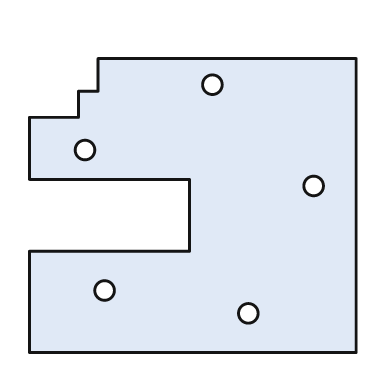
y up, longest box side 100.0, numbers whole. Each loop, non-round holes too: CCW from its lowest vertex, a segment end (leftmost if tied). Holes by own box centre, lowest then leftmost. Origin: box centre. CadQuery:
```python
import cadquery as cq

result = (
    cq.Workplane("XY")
    .moveTo(-50.0, -45.0)
    .lineTo(50.0, -45.0)
    .lineTo(50.0, 45.0)
    .lineTo(-29.0, 45.0)
    .lineTo(-29.0, 35.0)
    .lineTo(-35.0, 35.0)
    .lineTo(-35.0, 27.0)
    .lineTo(-50.0, 27.0)
    .lineTo(-50.0, 8.0)
    .lineTo(-1.0, 8.0)
    .lineTo(-1.0, -14.0)
    .lineTo(-50.0, -14.0)
    .close()
    .moveTo(17.0, -33.0)
    .circle(3.0)
    .moveTo(-27.0, -26.0)
    .circle(3.0)
    .moveTo(37.0, 6.0)
    .circle(3.0)
    .moveTo(-33.0, 17.0)
    .circle(3.0)
    .moveTo(6.0, 37.0)
    .circle(3.0)
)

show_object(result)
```